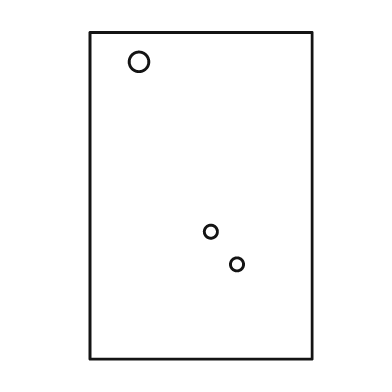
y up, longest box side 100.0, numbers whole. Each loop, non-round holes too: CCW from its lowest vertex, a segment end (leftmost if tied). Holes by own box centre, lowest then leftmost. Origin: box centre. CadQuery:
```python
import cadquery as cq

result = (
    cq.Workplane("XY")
    .moveTo(-34.0, -50.0)
    .lineTo(34.0, -50.0)
    .lineTo(34.0, 50.0)
    .lineTo(-34.0, 50.0)
    .close()
    .moveTo(11.0, -21.0)
    .circle(2.0)
    .moveTo(3.0, -11.0)
    .circle(2.0)
    .moveTo(-19.0, 41.0)
    .circle(3.0)
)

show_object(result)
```